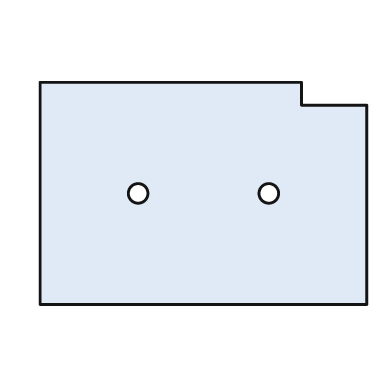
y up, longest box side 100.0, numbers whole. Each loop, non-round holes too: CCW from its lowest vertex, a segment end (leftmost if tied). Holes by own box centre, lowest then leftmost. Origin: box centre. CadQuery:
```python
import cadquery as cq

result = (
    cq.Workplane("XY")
    .moveTo(-50.0, -34.0)
    .lineTo(50.0, -34.0)
    .lineTo(50.0, 27.0)
    .lineTo(30.0, 27.0)
    .lineTo(30.0, 34.0)
    .lineTo(-50.0, 34.0)
    .close()
    .moveTo(-20.0, 0.0)
    .circle(3.0)
    .moveTo(20.0, 0.0)
    .circle(3.0)
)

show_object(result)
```